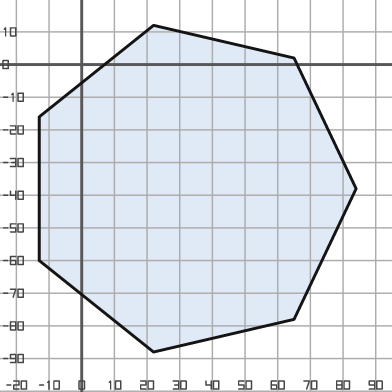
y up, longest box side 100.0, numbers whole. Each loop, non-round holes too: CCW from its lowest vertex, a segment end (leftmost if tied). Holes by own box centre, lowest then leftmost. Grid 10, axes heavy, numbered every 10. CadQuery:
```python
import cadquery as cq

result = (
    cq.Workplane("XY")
    .moveTo(22.0, -88.0)
    .lineTo(65.0, -78.0)
    .lineTo(84.0, -38.0)
    .lineTo(65.0, 2.0)
    .lineTo(22.0, 12.0)
    .lineTo(-13.0, -16.0)
    .lineTo(-13.0, -60.0)
    .close()
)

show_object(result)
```